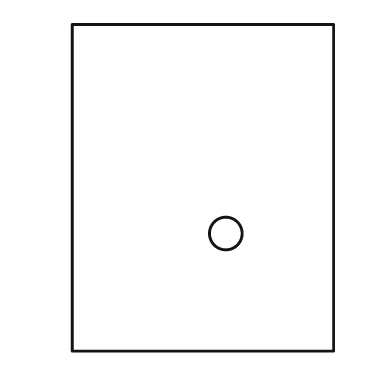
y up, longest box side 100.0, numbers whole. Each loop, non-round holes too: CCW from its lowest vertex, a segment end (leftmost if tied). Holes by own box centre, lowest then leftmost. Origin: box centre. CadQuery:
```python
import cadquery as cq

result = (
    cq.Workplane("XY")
    .moveTo(-40.0, -50.0)
    .lineTo(40.0, -50.0)
    .lineTo(40.0, 50.0)
    .lineTo(-40.0, 50.0)
    .close()
    .moveTo(7.0, -14.0)
    .circle(5.0)
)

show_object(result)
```